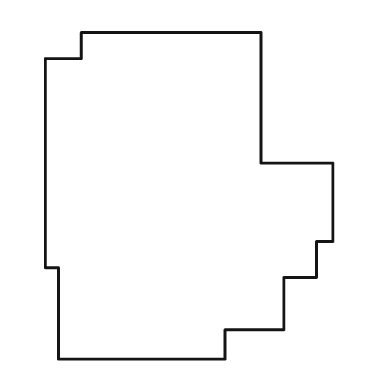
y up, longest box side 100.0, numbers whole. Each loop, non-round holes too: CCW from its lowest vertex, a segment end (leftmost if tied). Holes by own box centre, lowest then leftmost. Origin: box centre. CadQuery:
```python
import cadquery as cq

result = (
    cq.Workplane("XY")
    .moveTo(-40.0, -50.0)
    .lineTo(11.0, -50.0)
    .lineTo(11.0, -41.0)
    .lineTo(29.0, -41.0)
    .lineTo(29.0, -25.0)
    .lineTo(39.0, -25.0)
    .lineTo(39.0, -14.0)
    .lineTo(44.0, -14.0)
    .lineTo(44.0, 10.0)
    .lineTo(22.0, 10.0)
    .lineTo(22.0, 50.0)
    .lineTo(-33.0, 50.0)
    .lineTo(-33.0, 42.0)
    .lineTo(-44.0, 42.0)
    .lineTo(-44.0, -22.0)
    .lineTo(-40.0, -22.0)
    .close()
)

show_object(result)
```